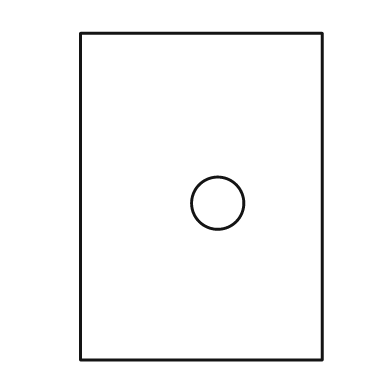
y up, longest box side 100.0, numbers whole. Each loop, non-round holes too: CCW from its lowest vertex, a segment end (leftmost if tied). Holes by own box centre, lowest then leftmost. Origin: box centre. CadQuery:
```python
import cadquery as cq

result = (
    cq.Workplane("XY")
    .moveTo(-37.0, -50.0)
    .lineTo(37.0, -50.0)
    .lineTo(37.0, 50.0)
    .lineTo(-37.0, 50.0)
    .close()
    .moveTo(5.0, -2.0)
    .circle(8.0)
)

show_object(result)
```